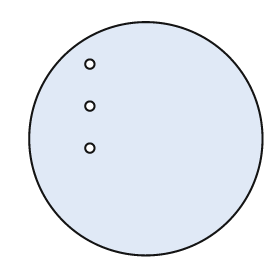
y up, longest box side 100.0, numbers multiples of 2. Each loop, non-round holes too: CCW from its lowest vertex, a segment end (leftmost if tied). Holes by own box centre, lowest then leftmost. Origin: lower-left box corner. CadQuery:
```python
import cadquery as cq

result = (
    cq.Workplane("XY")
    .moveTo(50.0, 50.0)
    .circle(50.0)
    .moveTo(26.0, 46.0)
    .circle(2.0)
    .moveTo(26.0, 64.0)
    .circle(2.0)
    .moveTo(26.0, 82.0)
    .circle(2.0)
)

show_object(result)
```